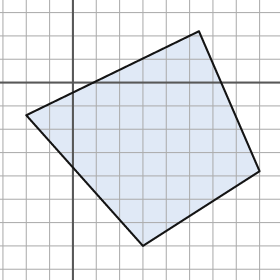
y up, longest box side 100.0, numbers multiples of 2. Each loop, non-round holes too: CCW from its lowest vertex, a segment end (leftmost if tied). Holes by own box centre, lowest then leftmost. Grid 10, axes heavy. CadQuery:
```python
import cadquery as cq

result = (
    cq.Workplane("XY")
    .moveTo(30.0, -70.0)
    .lineTo(80.0, -38.0)
    .lineTo(54.0, 22.0)
    .lineTo(-20.0, -14.0)
    .close()
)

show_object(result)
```